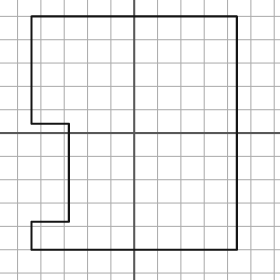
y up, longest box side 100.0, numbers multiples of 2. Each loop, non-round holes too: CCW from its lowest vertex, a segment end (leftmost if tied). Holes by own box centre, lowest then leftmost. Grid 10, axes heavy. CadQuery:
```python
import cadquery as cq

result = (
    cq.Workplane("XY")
    .moveTo(-44.0, -50.0)
    .lineTo(44.0, -50.0)
    .lineTo(44.0, 50.0)
    .lineTo(-44.0, 50.0)
    .lineTo(-44.0, 4.0)
    .lineTo(-28.0, 4.0)
    .lineTo(-28.0, -38.0)
    .lineTo(-44.0, -38.0)
    .close()
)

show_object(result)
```